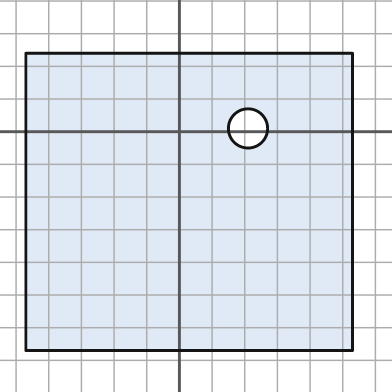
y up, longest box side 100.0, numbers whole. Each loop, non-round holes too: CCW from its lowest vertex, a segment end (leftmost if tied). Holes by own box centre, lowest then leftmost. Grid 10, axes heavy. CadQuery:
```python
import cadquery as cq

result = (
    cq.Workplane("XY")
    .moveTo(-47.0, -67.0)
    .lineTo(53.0, -67.0)
    .lineTo(53.0, 24.0)
    .lineTo(-47.0, 24.0)
    .close()
    .moveTo(21.0, 1.0)
    .circle(6.0)
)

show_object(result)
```